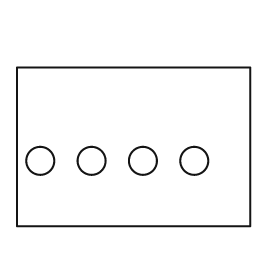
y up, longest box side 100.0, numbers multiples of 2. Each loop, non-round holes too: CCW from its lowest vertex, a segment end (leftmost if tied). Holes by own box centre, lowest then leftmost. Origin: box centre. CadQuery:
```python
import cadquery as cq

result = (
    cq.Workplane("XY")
    .moveTo(-50.0, -34.0)
    .lineTo(50.0, -34.0)
    .lineTo(50.0, 34.0)
    .lineTo(-50.0, 34.0)
    .close()
    .moveTo(-40.0, -6.0)
    .circle(6.0)
    .moveTo(-18.0, -6.0)
    .circle(6.0)
    .moveTo(4.0, -6.0)
    .circle(6.0)
    .moveTo(26.0, -6.0)
    .circle(6.0)
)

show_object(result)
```